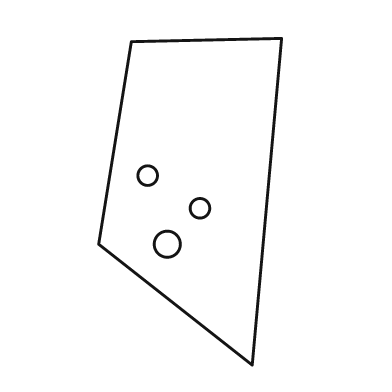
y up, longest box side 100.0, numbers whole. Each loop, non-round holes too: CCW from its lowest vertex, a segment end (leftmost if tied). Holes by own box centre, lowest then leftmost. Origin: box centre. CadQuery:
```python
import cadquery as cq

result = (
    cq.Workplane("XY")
    .moveTo(19.0, -50.0)
    .lineTo(28.0, 50.0)
    .lineTo(-18.0, 49.0)
    .lineTo(-28.0, -13.0)
    .close()
    .moveTo(-7.0, -13.0)
    .circle(4.0)
    .moveTo(3.0, -2.0)
    .circle(3.0)
    .moveTo(-13.0, 8.0)
    .circle(3.0)
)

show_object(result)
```